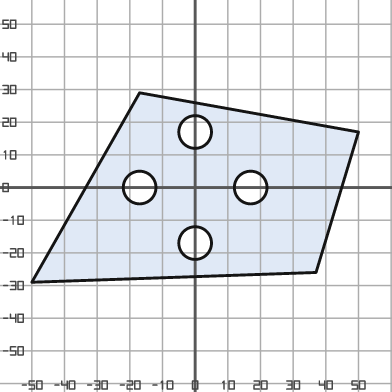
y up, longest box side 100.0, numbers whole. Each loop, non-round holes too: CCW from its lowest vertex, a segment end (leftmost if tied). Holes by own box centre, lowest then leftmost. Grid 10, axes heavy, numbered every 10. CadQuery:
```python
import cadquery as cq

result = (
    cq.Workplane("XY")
    .moveTo(-50.0, -29.0)
    .lineTo(37.0, -26.0)
    .lineTo(50.0, 17.0)
    .lineTo(-17.0, 29.0)
    .close()
    .moveTo(0.0, -17.0)
    .circle(5.0)
    .moveTo(-17.0, 0.0)
    .circle(5.0)
    .moveTo(17.0, 0.0)
    .circle(5.0)
    .moveTo(0.0, 17.0)
    .circle(5.0)
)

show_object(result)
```